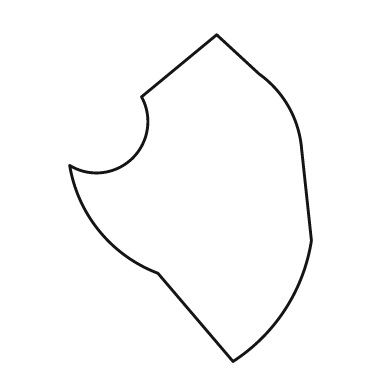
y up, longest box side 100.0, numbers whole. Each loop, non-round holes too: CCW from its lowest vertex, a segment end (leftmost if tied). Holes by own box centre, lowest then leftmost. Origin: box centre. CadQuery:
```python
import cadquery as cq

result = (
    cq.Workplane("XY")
    .moveTo(13.0, -50.0)
    .threePointArc((29.0, -34.0), (37.0, -13.0))
    .lineTo(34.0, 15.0)
    .threePointArc((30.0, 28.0), (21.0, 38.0))
    .lineTo(8.0, 50.0)
    .lineTo(-15.0, 31.0)
    .threePointArc((-18.0, 12.0), (-37.0, 10.0))
    .threePointArc((-28.0, -10.0), (-10.0, -23.0))
    .close()
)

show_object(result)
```